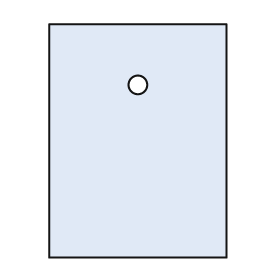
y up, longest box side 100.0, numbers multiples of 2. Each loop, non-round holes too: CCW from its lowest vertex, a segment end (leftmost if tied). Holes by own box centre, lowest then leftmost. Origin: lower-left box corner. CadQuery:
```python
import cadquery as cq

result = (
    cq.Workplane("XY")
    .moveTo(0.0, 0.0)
    .lineTo(76.0, 0.0)
    .lineTo(76.0, 100.0)
    .lineTo(0.0, 100.0)
    .close()
    .moveTo(38.0, 74.0)
    .circle(4.0)
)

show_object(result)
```